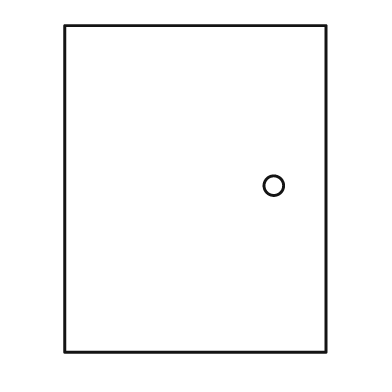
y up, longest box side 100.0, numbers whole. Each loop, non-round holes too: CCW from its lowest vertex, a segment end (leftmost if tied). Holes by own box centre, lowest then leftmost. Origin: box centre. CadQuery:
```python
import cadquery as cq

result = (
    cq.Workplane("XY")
    .moveTo(-40.0, -50.0)
    .lineTo(40.0, -50.0)
    .lineTo(40.0, 50.0)
    .lineTo(-40.0, 50.0)
    .close()
    .moveTo(24.0, 1.0)
    .circle(3.0)
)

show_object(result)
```